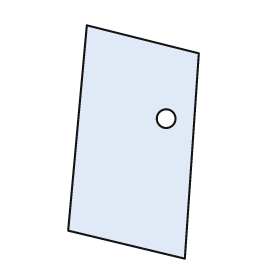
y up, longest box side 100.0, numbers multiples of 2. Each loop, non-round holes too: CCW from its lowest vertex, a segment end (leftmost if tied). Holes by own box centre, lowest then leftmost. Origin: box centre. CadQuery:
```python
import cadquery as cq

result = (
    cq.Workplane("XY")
    .moveTo(22.0, -50.0)
    .lineTo(28.0, 38.0)
    .lineTo(-20.0, 50.0)
    .lineTo(-28.0, -38.0)
    .close()
    .moveTo(14.0, 10.0)
    .circle(4.0)
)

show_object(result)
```